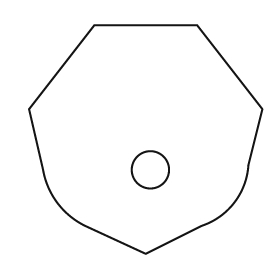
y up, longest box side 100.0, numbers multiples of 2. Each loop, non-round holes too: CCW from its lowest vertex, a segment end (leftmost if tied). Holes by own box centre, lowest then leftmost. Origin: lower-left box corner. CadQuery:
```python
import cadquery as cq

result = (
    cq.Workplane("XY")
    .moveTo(50.0, 0.0)
    .lineTo(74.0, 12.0)
    .threePointArc((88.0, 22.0), (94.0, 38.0))
    .lineTo(100.0, 62.0)
    .lineTo(72.0, 98.0)
    .lineTo(28.0, 98.0)
    .lineTo(0.0, 62.0)
    .lineTo(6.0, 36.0)
    .threePointArc((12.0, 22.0), (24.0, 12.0))
    .close()
    .moveTo(52.0, 36.0)
    .circle(8.0)
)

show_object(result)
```